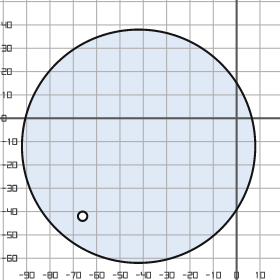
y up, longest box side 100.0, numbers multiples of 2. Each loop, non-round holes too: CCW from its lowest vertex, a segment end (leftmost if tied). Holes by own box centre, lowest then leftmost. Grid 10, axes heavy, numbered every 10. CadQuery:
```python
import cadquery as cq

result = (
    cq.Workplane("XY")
    .moveTo(-42.0, -12.0)
    .circle(50.0)
    .moveTo(-66.0, -42.0)
    .circle(2.0)
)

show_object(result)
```